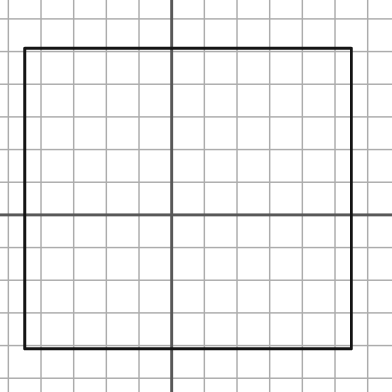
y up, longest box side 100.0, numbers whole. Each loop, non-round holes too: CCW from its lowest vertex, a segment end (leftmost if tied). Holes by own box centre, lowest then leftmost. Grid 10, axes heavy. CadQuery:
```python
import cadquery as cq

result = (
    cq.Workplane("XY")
    .moveTo(-45.0, -41.0)
    .lineTo(55.0, -41.0)
    .lineTo(55.0, 51.0)
    .lineTo(-45.0, 51.0)
    .close()
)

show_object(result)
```